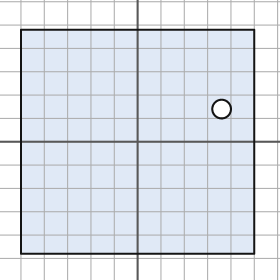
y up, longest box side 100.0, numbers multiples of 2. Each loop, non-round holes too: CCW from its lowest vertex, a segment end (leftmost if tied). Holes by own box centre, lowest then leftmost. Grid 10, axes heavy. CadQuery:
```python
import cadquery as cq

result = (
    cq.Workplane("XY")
    .moveTo(-50.0, -48.0)
    .lineTo(50.0, -48.0)
    .lineTo(50.0, 48.0)
    .lineTo(-50.0, 48.0)
    .close()
    .moveTo(36.0, 14.0)
    .circle(4.0)
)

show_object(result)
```